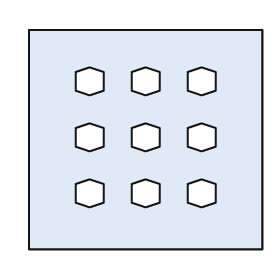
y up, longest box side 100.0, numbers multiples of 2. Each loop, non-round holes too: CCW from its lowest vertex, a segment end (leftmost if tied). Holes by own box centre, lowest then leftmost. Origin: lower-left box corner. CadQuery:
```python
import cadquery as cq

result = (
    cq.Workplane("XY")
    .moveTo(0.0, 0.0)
    .lineTo(100.0, 0.0)
    .lineTo(100.0, 94.0)
    .lineTo(0.0, 94.0)
    .close()
    .moveTo(26.0, 18.0)
    .lineTo(32.0, 20.0)
    .lineTo(32.0, 28.0)
    .lineTo(26.0, 30.0)
    .lineTo(20.0, 28.0)
    .lineTo(20.0, 20.0)
    .close()
    .moveTo(50.0, 18.0)
    .lineTo(56.0, 20.0)
    .lineTo(56.0, 28.0)
    .lineTo(50.0, 30.0)
    .lineTo(44.0, 28.0)
    .lineTo(44.0, 20.0)
    .close()
    .moveTo(74.0, 18.0)
    .lineTo(80.0, 20.0)
    .lineTo(80.0, 28.0)
    .lineTo(74.0, 30.0)
    .lineTo(68.0, 28.0)
    .lineTo(68.0, 20.0)
    .close()
    .moveTo(26.0, 42.0)
    .lineTo(32.0, 44.0)
    .lineTo(32.0, 52.0)
    .lineTo(26.0, 54.0)
    .lineTo(20.0, 52.0)
    .lineTo(20.0, 44.0)
    .close()
    .moveTo(50.0, 42.0)
    .lineTo(56.0, 44.0)
    .lineTo(56.0, 52.0)
    .lineTo(50.0, 54.0)
    .lineTo(44.0, 52.0)
    .lineTo(44.0, 44.0)
    .close()
    .moveTo(74.0, 42.0)
    .lineTo(80.0, 44.0)
    .lineTo(80.0, 52.0)
    .lineTo(74.0, 54.0)
    .lineTo(68.0, 52.0)
    .lineTo(68.0, 44.0)
    .close()
    .moveTo(26.0, 66.0)
    .lineTo(32.0, 68.0)
    .lineTo(32.0, 76.0)
    .lineTo(26.0, 78.0)
    .lineTo(20.0, 76.0)
    .lineTo(20.0, 68.0)
    .close()
    .moveTo(50.0, 66.0)
    .lineTo(56.0, 68.0)
    .lineTo(56.0, 76.0)
    .lineTo(50.0, 78.0)
    .lineTo(44.0, 76.0)
    .lineTo(44.0, 68.0)
    .close()
    .moveTo(74.0, 66.0)
    .lineTo(80.0, 68.0)
    .lineTo(80.0, 76.0)
    .lineTo(74.0, 78.0)
    .lineTo(68.0, 76.0)
    .lineTo(68.0, 68.0)
    .close()
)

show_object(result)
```